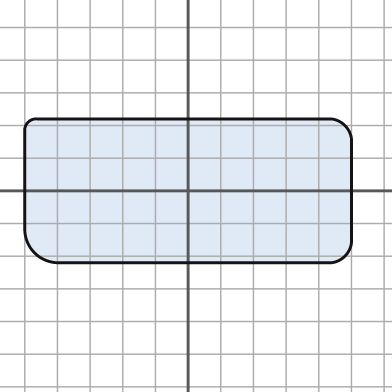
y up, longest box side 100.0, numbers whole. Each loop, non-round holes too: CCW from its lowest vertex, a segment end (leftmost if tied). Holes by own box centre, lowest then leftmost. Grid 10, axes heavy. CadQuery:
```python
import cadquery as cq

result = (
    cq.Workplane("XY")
    .moveTo(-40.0, -22.0)
    .lineTo(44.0, -22.0)
    .threePointArc((48.0, -20.0), (50.0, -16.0))
    .lineTo(50.0, 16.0)
    .threePointArc((48.0, 20.0), (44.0, 22.0))
    .lineTo(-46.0, 22.0)
    .threePointArc((-49.0, 21.0), (-50.0, 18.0))
    .lineTo(-50.0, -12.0)
    .threePointArc((-47.0, -19.0), (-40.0, -22.0))
    .close()
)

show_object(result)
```